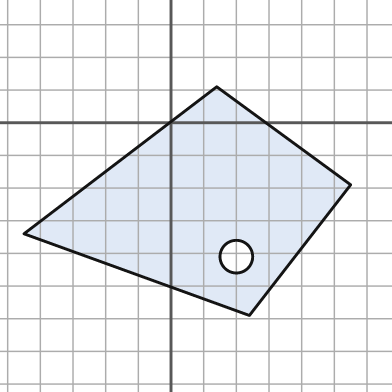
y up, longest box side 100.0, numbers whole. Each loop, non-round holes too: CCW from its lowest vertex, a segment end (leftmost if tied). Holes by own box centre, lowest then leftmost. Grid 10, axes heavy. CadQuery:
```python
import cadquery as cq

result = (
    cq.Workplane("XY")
    .moveTo(24.0, -59.0)
    .lineTo(55.0, -19.0)
    .lineTo(14.0, 11.0)
    .lineTo(-45.0, -34.0)
    .close()
    .moveTo(20.0, -41.0)
    .circle(5.0)
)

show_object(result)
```